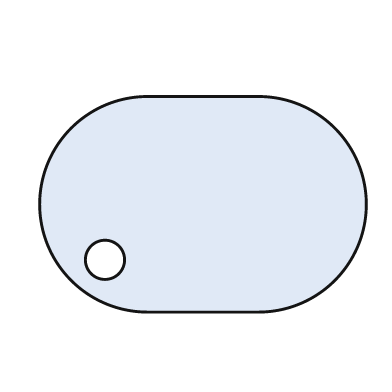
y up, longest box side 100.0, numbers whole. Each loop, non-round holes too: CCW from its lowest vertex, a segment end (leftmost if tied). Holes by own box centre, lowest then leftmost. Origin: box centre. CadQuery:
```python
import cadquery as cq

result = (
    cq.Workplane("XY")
    .moveTo(-17.0, -33.0)
    .lineTo(17.0, -33.0)
    .threePointArc((50.0, 0.0), (17.0, 33.0))
    .lineTo(-17.0, 33.0)
    .threePointArc((-50.0, 0.0), (-17.0, -33.0))
    .close()
    .moveTo(-30.0, -17.0)
    .circle(6.0)
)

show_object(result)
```